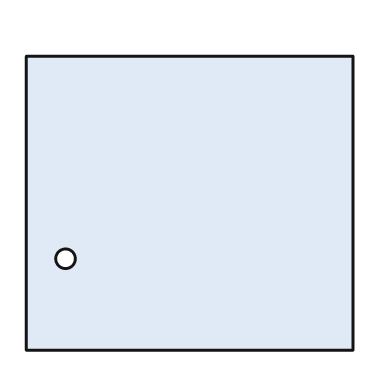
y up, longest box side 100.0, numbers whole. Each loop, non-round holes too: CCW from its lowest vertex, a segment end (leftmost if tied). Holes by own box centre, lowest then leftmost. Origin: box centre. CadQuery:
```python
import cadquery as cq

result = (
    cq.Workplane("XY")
    .moveTo(-50.0, -45.0)
    .lineTo(50.0, -45.0)
    .lineTo(50.0, 45.0)
    .lineTo(-50.0, 45.0)
    .close()
    .moveTo(-38.0, -17.0)
    .circle(3.0)
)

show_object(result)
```